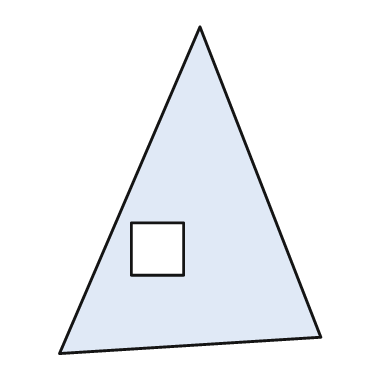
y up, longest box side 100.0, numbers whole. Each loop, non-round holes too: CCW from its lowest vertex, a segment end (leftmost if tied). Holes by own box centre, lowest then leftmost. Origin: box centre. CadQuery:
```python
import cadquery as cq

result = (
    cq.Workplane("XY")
    .moveTo(-40.0, -50.0)
    .lineTo(40.0, -45.0)
    .lineTo(3.0, 50.0)
    .close()
    .moveTo(-18.0, -26.0)
    .lineTo(-2.0, -26.0)
    .lineTo(-2.0, -10.0)
    .lineTo(-18.0, -10.0)
    .close()
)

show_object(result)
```